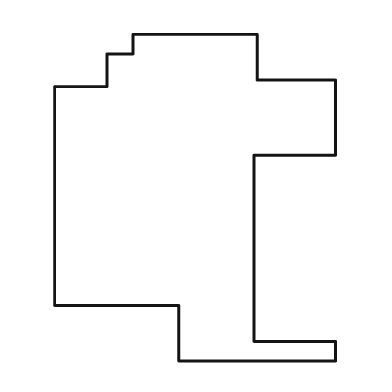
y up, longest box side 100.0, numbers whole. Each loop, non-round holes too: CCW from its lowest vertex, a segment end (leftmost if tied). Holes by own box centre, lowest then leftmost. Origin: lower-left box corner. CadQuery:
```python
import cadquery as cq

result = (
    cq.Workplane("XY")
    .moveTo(38.0, 0.0)
    .lineTo(86.0, 0.0)
    .lineTo(86.0, 6.0)
    .lineTo(61.0, 6.0)
    .lineTo(61.0, 63.0)
    .lineTo(86.0, 63.0)
    .lineTo(86.0, 86.0)
    .lineTo(62.0, 86.0)
    .lineTo(62.0, 100.0)
    .lineTo(24.0, 100.0)
    .lineTo(24.0, 94.0)
    .lineTo(16.0, 94.0)
    .lineTo(16.0, 84.0)
    .lineTo(0.0, 84.0)
    .lineTo(0.0, 17.0)
    .lineTo(38.0, 17.0)
    .close()
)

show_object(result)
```